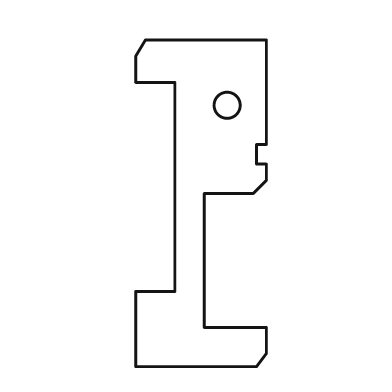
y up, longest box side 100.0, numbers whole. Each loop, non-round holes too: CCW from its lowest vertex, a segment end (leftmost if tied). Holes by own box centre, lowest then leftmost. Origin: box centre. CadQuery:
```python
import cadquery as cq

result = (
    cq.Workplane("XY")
    .moveTo(-20.0, -50.0)
    .lineTo(17.0, -50.0)
    .lineTo(20.0, -46.0)
    .lineTo(20.0, -38.0)
    .lineTo(1.0, -38.0)
    .lineTo(1.0, 3.0)
    .lineTo(16.0, 3.0)
    .lineTo(20.0, 7.0)
    .lineTo(20.0, 12.0)
    .lineTo(17.0, 12.0)
    .lineTo(17.0, 18.0)
    .lineTo(20.0, 18.0)
    .lineTo(20.0, 50.0)
    .lineTo(-17.0, 50.0)
    .lineTo(-20.0, 45.0)
    .lineTo(-20.0, 37.0)
    .lineTo(-8.0, 37.0)
    .lineTo(-8.0, -27.0)
    .lineTo(-20.0, -27.0)
    .close()
    .moveTo(8.0, 30.0)
    .circle(4.0)
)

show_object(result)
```